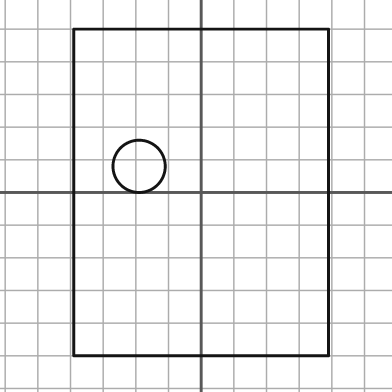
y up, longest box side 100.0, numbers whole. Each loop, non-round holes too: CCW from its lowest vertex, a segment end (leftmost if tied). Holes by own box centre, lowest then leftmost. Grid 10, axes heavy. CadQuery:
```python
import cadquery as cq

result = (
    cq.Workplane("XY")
    .moveTo(-39.0, -50.0)
    .lineTo(39.0, -50.0)
    .lineTo(39.0, 50.0)
    .lineTo(-39.0, 50.0)
    .close()
    .moveTo(-19.0, 8.0)
    .circle(8.0)
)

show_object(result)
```